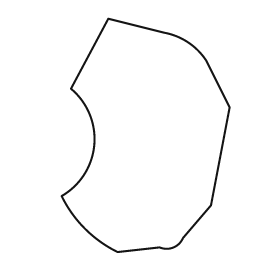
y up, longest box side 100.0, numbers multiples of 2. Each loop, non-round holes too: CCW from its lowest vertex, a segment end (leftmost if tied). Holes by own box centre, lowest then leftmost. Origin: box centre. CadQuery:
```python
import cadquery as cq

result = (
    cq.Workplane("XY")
    .moveTo(-12.0, -50.0)
    .lineTo(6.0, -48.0)
    .threePointArc((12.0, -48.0), (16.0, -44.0))
    .lineTo(28.0, -30.0)
    .lineTo(36.0, 12.0)
    .lineTo(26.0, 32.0)
    .threePointArc((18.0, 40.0), (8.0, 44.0))
    .lineTo(-16.0, 50.0)
    .lineTo(-32.0, 20.0)
    .threePointArc((-22.0, -4.0), (-36.0, -26.0))
    .threePointArc((-26.0, -40.0), (-12.0, -50.0))
    .close()
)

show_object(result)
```